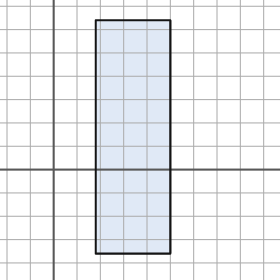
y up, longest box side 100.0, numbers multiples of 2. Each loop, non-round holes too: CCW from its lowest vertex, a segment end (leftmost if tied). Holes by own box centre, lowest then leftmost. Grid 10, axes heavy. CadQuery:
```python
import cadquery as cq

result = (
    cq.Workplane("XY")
    .moveTo(18.0, -36.0)
    .lineTo(50.0, -36.0)
    .lineTo(50.0, 64.0)
    .lineTo(18.0, 64.0)
    .close()
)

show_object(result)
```